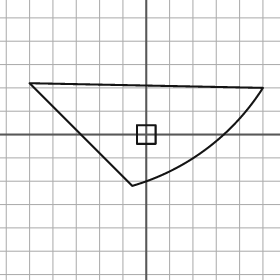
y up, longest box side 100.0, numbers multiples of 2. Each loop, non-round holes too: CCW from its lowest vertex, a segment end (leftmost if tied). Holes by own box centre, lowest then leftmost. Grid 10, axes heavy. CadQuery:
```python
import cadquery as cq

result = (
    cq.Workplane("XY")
    .moveTo(-6.0, -22.0)
    .threePointArc((26.0, -6.0), (50.0, 20.0))
    .lineTo(-50.0, 22.0)
    .close()
    .moveTo(-4.0, -4.0)
    .lineTo(4.0, -4.0)
    .lineTo(4.0, 4.0)
    .lineTo(-4.0, 4.0)
    .close()
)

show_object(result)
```